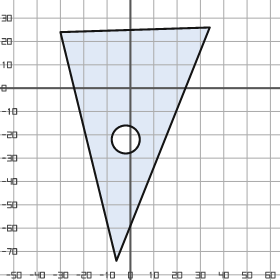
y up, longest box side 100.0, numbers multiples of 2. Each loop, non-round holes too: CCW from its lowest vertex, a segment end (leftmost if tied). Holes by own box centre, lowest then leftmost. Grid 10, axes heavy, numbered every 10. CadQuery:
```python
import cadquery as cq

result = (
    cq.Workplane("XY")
    .moveTo(-6.0, -74.0)
    .lineTo(34.0, 26.0)
    .lineTo(-30.0, 24.0)
    .close()
    .moveTo(-2.0, -22.0)
    .circle(6.0)
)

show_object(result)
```